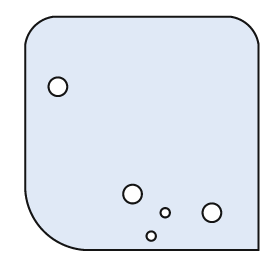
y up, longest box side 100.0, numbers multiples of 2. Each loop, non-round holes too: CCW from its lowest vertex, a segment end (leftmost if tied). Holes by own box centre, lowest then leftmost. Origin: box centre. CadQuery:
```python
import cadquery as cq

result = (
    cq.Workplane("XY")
    .moveTo(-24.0, -50.0)
    .lineTo(50.0, -50.0)
    .lineTo(50.0, 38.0)
    .threePointArc((46.0, 46.0), (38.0, 50.0))
    .lineTo(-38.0, 50.0)
    .threePointArc((-46.0, 46.0), (-50.0, 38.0))
    .lineTo(-50.0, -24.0)
    .threePointArc((-42.0, -42.0), (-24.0, -50.0))
    .close()
    .moveTo(4.0, -44.0)
    .circle(2.0)
    .moveTo(10.0, -34.0)
    .circle(2.0)
    .moveTo(30.0, -34.0)
    .circle(4.0)
    .moveTo(-4.0, -26.0)
    .circle(4.0)
    .moveTo(-36.0, 20.0)
    .circle(4.0)
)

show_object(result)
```